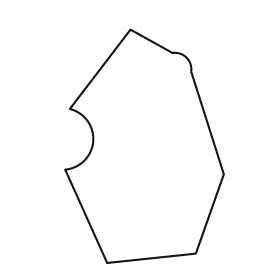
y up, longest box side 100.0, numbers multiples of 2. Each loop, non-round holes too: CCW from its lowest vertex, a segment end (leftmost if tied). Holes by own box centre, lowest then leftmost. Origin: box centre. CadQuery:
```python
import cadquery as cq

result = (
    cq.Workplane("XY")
    .moveTo(-16.0, -50.0)
    .lineTo(22.0, -46.0)
    .lineTo(34.0, -12.0)
    .lineTo(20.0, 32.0)
    .threePointArc((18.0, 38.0), (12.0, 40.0))
    .lineTo(-6.0, 50.0)
    .lineTo(-32.0, 16.0)
    .threePointArc((-22.0, 2.0), (-34.0, -10.0))
    .close()
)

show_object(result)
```